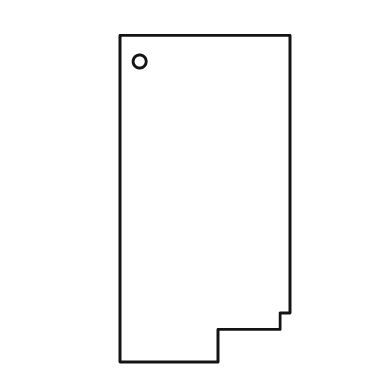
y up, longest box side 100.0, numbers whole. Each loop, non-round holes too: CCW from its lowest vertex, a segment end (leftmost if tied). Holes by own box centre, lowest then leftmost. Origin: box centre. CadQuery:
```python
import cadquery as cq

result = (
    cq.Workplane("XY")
    .moveTo(-26.0, -50.0)
    .lineTo(4.0, -50.0)
    .lineTo(4.0, -40.0)
    .lineTo(23.0, -40.0)
    .lineTo(23.0, -35.0)
    .lineTo(26.0, -35.0)
    .lineTo(26.0, 50.0)
    .lineTo(-26.0, 50.0)
    .close()
    .moveTo(-20.0, 42.0)
    .circle(2.0)
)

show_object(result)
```